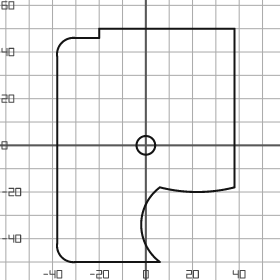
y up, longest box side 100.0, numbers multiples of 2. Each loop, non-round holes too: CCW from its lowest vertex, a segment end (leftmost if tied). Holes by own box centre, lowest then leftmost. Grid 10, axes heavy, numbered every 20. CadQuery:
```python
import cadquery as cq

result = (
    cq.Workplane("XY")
    .moveTo(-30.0, -50.0)
    .lineTo(6.0, -50.0)
    .threePointArc((-2.0, -34.0), (6.0, -18.0))
    .threePointArc((22.0, -20.0), (38.0, -18.0))
    .lineTo(38.0, 50.0)
    .lineTo(-20.0, 50.0)
    .lineTo(-20.0, 46.0)
    .lineTo(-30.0, 46.0)
    .threePointArc((-36.0, 44.0), (-38.0, 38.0))
    .lineTo(-38.0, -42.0)
    .threePointArc((-36.0, -48.0), (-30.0, -50.0))
    .close()
    .moveTo(0.0, 0.0)
    .circle(4.0)
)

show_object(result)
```